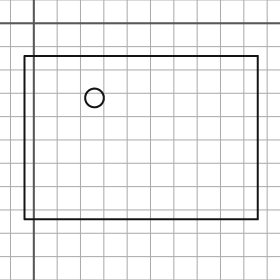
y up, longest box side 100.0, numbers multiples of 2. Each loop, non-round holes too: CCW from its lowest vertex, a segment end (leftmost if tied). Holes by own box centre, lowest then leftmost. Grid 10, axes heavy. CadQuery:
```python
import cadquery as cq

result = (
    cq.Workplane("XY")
    .moveTo(-4.0, -84.0)
    .lineTo(96.0, -84.0)
    .lineTo(96.0, -14.0)
    .lineTo(-4.0, -14.0)
    .close()
    .moveTo(26.0, -32.0)
    .circle(4.0)
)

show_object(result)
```